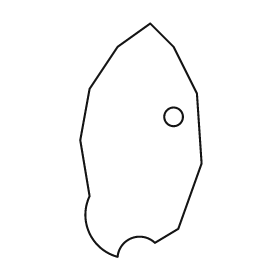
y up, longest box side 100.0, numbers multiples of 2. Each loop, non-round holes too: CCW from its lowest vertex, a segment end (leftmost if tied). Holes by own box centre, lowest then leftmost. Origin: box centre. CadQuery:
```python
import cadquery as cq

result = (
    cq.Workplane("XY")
    .moveTo(-10.0, -50.0)
    .threePointArc((-4.0, -42.0), (6.0, -44.0))
    .lineTo(16.0, -38.0)
    .lineTo(26.0, -10.0)
    .lineTo(24.0, 20.0)
    .lineTo(14.0, 40.0)
    .lineTo(4.0, 50.0)
    .lineTo(-10.0, 40.0)
    .lineTo(-22.0, 22.0)
    .lineTo(-26.0, 0.0)
    .lineTo(-22.0, -24.0)
    .threePointArc((-22.0, -40.0), (-10.0, -50.0))
    .close()
    .moveTo(14.0, 10.0)
    .circle(4.0)
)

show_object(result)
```